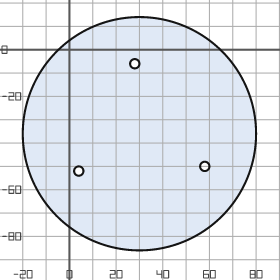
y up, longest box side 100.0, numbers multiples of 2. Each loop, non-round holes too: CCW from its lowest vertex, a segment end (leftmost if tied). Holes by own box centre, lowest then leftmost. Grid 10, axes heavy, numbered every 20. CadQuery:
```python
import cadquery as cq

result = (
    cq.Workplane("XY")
    .moveTo(30.0, -36.0)
    .circle(50.0)
    .moveTo(4.0, -52.0)
    .circle(2.0)
    .moveTo(58.0, -50.0)
    .circle(2.0)
    .moveTo(28.0, -6.0)
    .circle(2.0)
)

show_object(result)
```